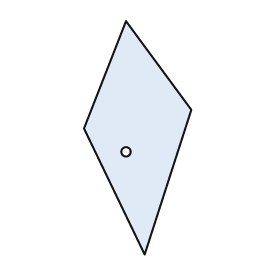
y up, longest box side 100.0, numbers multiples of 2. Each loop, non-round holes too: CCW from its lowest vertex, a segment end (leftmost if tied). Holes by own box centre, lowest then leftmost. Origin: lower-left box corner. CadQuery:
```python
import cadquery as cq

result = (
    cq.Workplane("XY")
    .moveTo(26.0, 0.0)
    .lineTo(46.0, 62.0)
    .lineTo(18.0, 100.0)
    .lineTo(0.0, 54.0)
    .close()
    .moveTo(18.0, 44.0)
    .circle(2.0)
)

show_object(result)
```